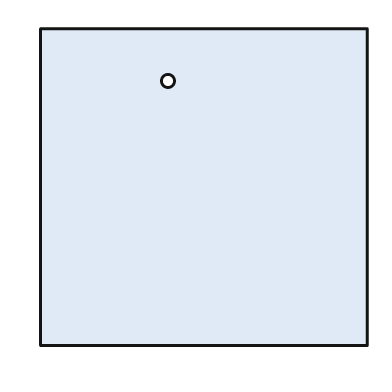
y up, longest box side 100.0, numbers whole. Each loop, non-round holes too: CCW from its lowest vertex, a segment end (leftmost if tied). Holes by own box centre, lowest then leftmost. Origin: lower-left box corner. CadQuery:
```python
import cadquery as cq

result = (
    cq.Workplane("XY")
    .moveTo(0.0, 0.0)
    .lineTo(100.0, 0.0)
    .lineTo(100.0, 97.0)
    .lineTo(0.0, 97.0)
    .close()
    .moveTo(39.0, 81.0)
    .circle(2.0)
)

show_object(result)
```